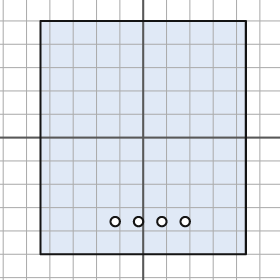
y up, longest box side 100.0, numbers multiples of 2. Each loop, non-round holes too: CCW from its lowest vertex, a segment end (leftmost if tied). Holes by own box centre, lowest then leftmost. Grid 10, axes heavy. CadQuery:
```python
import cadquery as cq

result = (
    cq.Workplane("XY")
    .moveTo(-44.0, -50.0)
    .lineTo(44.0, -50.0)
    .lineTo(44.0, 50.0)
    .lineTo(-44.0, 50.0)
    .close()
    .moveTo(-12.0, -36.0)
    .circle(2.0)
    .moveTo(-2.0, -36.0)
    .circle(2.0)
    .moveTo(8.0, -36.0)
    .circle(2.0)
    .moveTo(18.0, -36.0)
    .circle(2.0)
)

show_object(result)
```